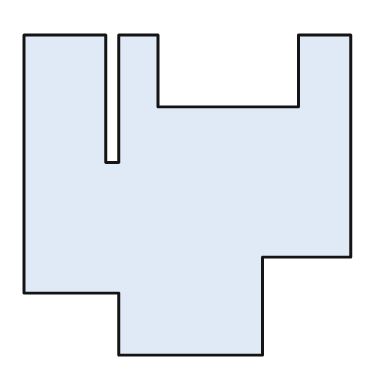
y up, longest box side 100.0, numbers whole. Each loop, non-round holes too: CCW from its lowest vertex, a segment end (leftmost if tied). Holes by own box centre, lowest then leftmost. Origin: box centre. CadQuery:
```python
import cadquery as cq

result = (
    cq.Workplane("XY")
    .moveTo(-21.0, -49.0)
    .lineTo(23.0, -49.0)
    .lineTo(23.0, -19.0)
    .lineTo(50.0, -19.0)
    .lineTo(50.0, 49.0)
    .lineTo(34.0, 49.0)
    .lineTo(34.0, 27.0)
    .lineTo(-9.0, 27.0)
    .lineTo(-9.0, 49.0)
    .lineTo(-21.0, 49.0)
    .lineTo(-21.0, 10.0)
    .lineTo(-25.0, 10.0)
    .lineTo(-25.0, 49.0)
    .lineTo(-50.0, 49.0)
    .lineTo(-50.0, -30.0)
    .lineTo(-21.0, -30.0)
    .close()
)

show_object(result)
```